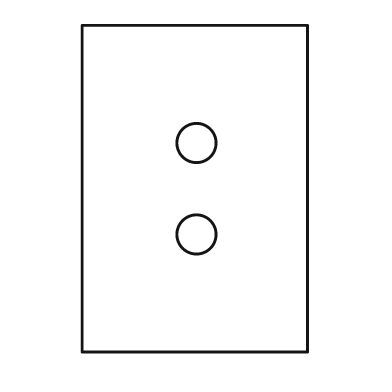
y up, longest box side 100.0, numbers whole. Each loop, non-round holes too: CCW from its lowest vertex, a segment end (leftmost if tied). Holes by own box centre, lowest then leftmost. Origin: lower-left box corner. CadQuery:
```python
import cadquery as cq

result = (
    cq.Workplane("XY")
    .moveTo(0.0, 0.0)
    .lineTo(69.0, 0.0)
    .lineTo(69.0, 100.0)
    .lineTo(0.0, 100.0)
    .close()
    .moveTo(35.0, 36.0)
    .circle(6.0)
    .moveTo(35.0, 64.0)
    .circle(6.0)
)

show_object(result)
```